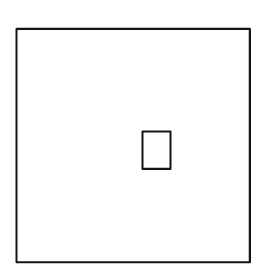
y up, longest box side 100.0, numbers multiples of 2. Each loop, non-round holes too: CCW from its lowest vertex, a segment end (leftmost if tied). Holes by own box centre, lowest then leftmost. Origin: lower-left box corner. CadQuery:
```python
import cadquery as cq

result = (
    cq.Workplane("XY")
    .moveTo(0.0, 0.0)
    .lineTo(100.0, 0.0)
    .lineTo(100.0, 100.0)
    .lineTo(0.0, 100.0)
    .close()
    .moveTo(54.0, 40.0)
    .lineTo(66.0, 40.0)
    .lineTo(66.0, 56.0)
    .lineTo(54.0, 56.0)
    .close()
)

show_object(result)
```